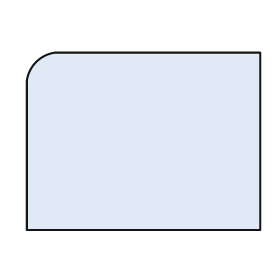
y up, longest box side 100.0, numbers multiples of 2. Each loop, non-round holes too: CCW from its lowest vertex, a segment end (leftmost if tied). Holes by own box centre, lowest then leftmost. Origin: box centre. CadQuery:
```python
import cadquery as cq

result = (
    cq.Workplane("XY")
    .moveTo(-50.0, -38.0)
    .lineTo(50.0, -38.0)
    .lineTo(50.0, 38.0)
    .lineTo(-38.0, 38.0)
    .threePointArc((-46.0, 34.0), (-50.0, 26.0))
    .close()
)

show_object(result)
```